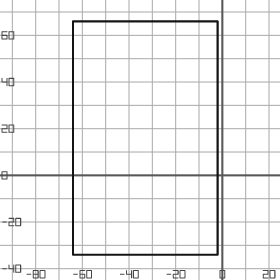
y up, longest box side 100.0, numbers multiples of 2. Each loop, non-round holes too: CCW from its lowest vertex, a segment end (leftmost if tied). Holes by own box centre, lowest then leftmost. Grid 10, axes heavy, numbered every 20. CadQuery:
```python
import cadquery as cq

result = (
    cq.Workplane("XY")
    .moveTo(-64.0, -34.0)
    .lineTo(-2.0, -34.0)
    .lineTo(-2.0, 66.0)
    .lineTo(-64.0, 66.0)
    .close()
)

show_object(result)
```